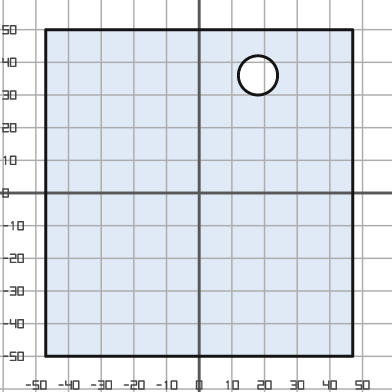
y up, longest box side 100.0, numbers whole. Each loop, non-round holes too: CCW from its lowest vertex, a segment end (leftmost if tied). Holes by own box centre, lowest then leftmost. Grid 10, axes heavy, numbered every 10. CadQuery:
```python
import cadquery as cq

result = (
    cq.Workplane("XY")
    .moveTo(-47.0, -50.0)
    .lineTo(47.0, -50.0)
    .lineTo(47.0, 50.0)
    .lineTo(-47.0, 50.0)
    .close()
    .moveTo(18.0, 36.0)
    .circle(6.0)
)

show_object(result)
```